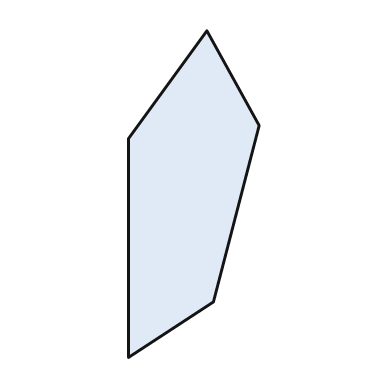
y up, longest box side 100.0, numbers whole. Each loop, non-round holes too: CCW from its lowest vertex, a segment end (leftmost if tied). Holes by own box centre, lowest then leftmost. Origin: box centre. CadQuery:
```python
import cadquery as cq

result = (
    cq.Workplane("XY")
    .moveTo(-20.0, -50.0)
    .lineTo(6.0, -33.0)
    .lineTo(20.0, 21.0)
    .lineTo(4.0, 50.0)
    .lineTo(-20.0, 17.0)
    .close()
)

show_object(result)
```